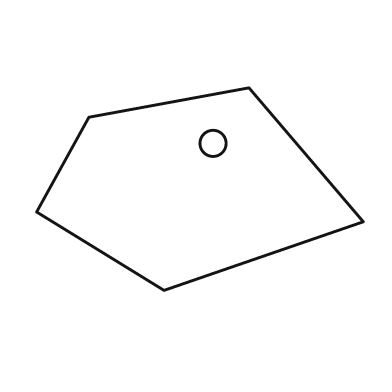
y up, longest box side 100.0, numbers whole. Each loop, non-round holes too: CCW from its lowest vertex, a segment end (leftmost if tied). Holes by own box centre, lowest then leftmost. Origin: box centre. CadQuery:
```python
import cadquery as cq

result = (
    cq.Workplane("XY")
    .moveTo(-11.0, -31.0)
    .lineTo(50.0, -10.0)
    .lineTo(15.0, 31.0)
    .lineTo(-34.0, 22.0)
    .lineTo(-50.0, -7.0)
    .close()
    .moveTo(4.0, 14.0)
    .circle(4.0)
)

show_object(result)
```